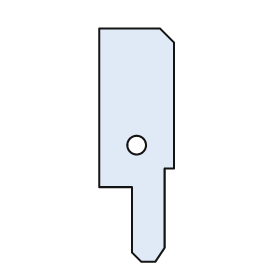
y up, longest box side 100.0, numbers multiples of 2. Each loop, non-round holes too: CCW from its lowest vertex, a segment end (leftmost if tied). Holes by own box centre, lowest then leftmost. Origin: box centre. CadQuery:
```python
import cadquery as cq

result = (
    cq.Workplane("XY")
    .moveTo(2.0, -50.0)
    .lineTo(8.0, -50.0)
    .lineTo(12.0, -44.0)
    .lineTo(12.0, -10.0)
    .lineTo(16.0, -10.0)
    .lineTo(16.0, 44.0)
    .lineTo(10.0, 50.0)
    .lineTo(-16.0, 50.0)
    .lineTo(-16.0, -18.0)
    .lineTo(-2.0, -18.0)
    .lineTo(-2.0, -46.0)
    .close()
    .moveTo(0.0, 0.0)
    .circle(4.0)
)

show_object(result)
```